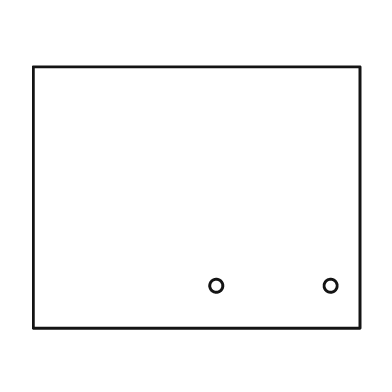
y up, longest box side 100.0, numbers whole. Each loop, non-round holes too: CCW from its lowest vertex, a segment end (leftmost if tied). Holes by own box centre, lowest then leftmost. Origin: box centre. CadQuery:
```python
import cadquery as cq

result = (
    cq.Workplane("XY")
    .moveTo(-50.0, -40.0)
    .lineTo(50.0, -40.0)
    .lineTo(50.0, 40.0)
    .lineTo(-50.0, 40.0)
    .close()
    .moveTo(6.0, -27.0)
    .circle(2.0)
    .moveTo(41.0, -27.0)
    .circle(2.0)
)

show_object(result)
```